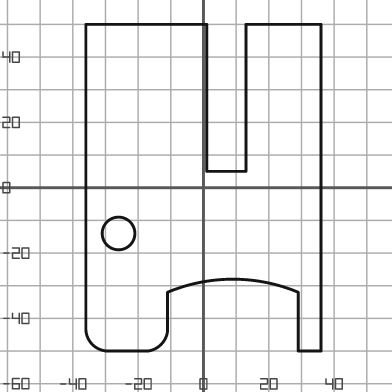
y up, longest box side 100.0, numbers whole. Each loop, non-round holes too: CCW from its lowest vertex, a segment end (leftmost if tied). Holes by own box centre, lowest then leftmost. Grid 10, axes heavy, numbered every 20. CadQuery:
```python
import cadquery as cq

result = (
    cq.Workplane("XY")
    .moveTo(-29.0, -50.0)
    .lineTo(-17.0, -50.0)
    .threePointArc((-13.0, -48.0), (-11.0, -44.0))
    .lineTo(-11.0, -32.0)
    .threePointArc((9.0, -28.0), (29.0, -32.0))
    .lineTo(29.0, -50.0)
    .lineTo(36.0, -50.0)
    .lineTo(36.0, 50.0)
    .lineTo(13.0, 50.0)
    .lineTo(13.0, 5.0)
    .lineTo(1.0, 5.0)
    .lineTo(1.0, 50.0)
    .lineTo(-36.0, 50.0)
    .lineTo(-36.0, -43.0)
    .threePointArc((-34.0, -48.0), (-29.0, -50.0))
    .close()
    .moveTo(-26.0, -14.0)
    .circle(5.0)
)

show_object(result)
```